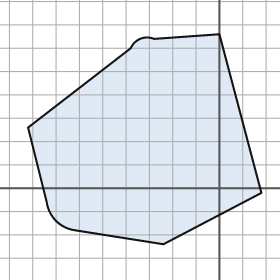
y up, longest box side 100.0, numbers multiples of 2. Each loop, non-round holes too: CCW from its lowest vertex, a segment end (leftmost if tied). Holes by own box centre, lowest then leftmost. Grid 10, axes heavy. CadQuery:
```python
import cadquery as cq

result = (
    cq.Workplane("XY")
    .moveTo(-24.0, -24.0)
    .lineTo(18.0, -2.0)
    .lineTo(0.0, 66.0)
    .lineTo(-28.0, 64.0)
    .threePointArc((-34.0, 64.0), (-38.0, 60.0))
    .lineTo(-82.0, 26.0)
    .lineTo(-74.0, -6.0)
    .threePointArc((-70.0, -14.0), (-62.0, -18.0))
    .close()
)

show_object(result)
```